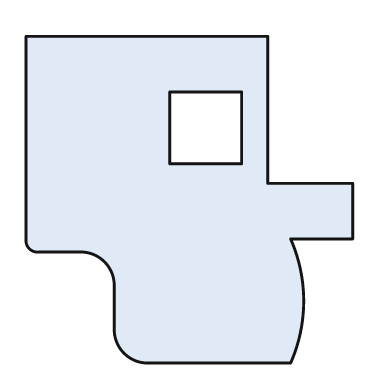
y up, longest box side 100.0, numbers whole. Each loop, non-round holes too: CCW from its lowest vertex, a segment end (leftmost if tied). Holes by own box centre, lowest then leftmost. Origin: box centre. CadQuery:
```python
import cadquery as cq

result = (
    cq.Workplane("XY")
    .moveTo(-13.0, -50.0)
    .lineTo(31.0, -50.0)
    .threePointArc((35.0, -31.0), (31.0, -12.0))
    .lineTo(50.0, -12.0)
    .lineTo(50.0, 5.0)
    .lineTo(24.0, 5.0)
    .lineTo(24.0, 50.0)
    .lineTo(-50.0, 50.0)
    .lineTo(-50.0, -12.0)
    .threePointArc((-49.0, -15.0), (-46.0, -16.0))
    .lineTo(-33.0, -16.0)
    .threePointArc((-26.0, -19.0), (-23.0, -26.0))
    .lineTo(-23.0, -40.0)
    .threePointArc((-20.0, -47.0), (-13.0, -50.0))
    .close()
    .moveTo(-6.0, 11.0)
    .lineTo(16.0, 11.0)
    .lineTo(16.0, 33.0)
    .lineTo(-6.0, 33.0)
    .close()
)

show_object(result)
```